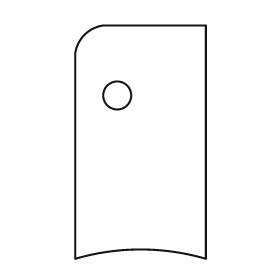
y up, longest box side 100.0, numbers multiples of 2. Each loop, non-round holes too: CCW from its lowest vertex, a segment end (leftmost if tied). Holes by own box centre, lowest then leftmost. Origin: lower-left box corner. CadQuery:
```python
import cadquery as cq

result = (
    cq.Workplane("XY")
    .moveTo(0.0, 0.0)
    .threePointArc((28.0, 4.0), (56.0, 0.0))
    .lineTo(56.0, 100.0)
    .lineTo(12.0, 100.0)
    .threePointArc((4.0, 96.0), (0.0, 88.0))
    .close()
    .moveTo(18.0, 70.0)
    .circle(6.0)
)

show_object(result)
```